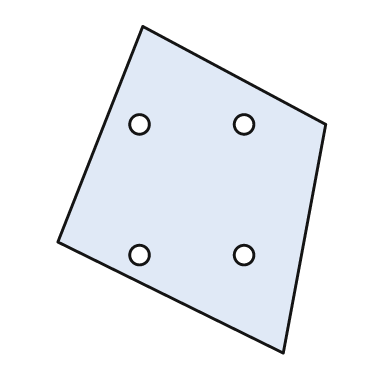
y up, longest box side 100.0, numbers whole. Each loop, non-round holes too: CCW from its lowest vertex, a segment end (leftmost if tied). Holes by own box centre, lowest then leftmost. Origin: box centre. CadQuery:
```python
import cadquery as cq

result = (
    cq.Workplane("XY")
    .moveTo(28.0, -50.0)
    .lineTo(41.0, 20.0)
    .lineTo(-15.0, 50.0)
    .lineTo(-41.0, -16.0)
    .close()
    .moveTo(-16.0, -20.0)
    .circle(3.0)
    .moveTo(16.0, -20.0)
    .circle(3.0)
    .moveTo(-16.0, 20.0)
    .circle(3.0)
    .moveTo(16.0, 20.0)
    .circle(3.0)
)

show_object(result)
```